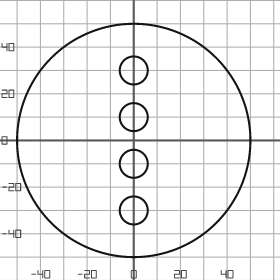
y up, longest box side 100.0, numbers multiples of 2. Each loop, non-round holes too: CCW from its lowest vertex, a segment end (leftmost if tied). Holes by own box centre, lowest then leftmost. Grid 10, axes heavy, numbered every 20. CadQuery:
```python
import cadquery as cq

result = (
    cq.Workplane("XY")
    .moveTo(0.0, 0.0)
    .circle(50.0)
    .moveTo(0.0, -30.0)
    .circle(6.0)
    .moveTo(0.0, -10.0)
    .circle(6.0)
    .moveTo(0.0, 10.0)
    .circle(6.0)
    .moveTo(0.0, 30.0)
    .circle(6.0)
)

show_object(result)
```